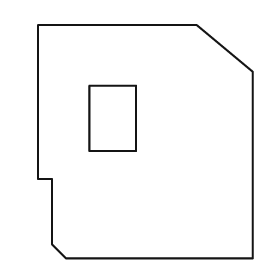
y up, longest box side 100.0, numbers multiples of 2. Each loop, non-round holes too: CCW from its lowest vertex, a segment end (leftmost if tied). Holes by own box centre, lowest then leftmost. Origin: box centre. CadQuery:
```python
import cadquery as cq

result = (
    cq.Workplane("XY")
    .moveTo(-34.0, -50.0)
    .lineTo(46.0, -50.0)
    .lineTo(46.0, 30.0)
    .lineTo(22.0, 50.0)
    .lineTo(-46.0, 50.0)
    .lineTo(-46.0, -16.0)
    .lineTo(-40.0, -16.0)
    .lineTo(-40.0, -44.0)
    .close()
    .moveTo(-24.0, -4.0)
    .lineTo(-4.0, -4.0)
    .lineTo(-4.0, 24.0)
    .lineTo(-24.0, 24.0)
    .close()
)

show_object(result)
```